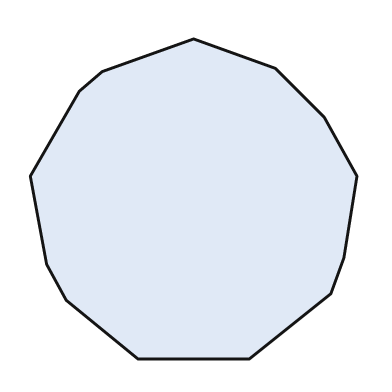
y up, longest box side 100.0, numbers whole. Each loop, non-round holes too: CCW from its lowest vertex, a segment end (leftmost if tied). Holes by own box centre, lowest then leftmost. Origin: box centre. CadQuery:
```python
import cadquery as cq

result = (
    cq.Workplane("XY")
    .moveTo(-17.0, -49.0)
    .lineTo(17.0, -49.0)
    .lineTo(42.0, -29.0)
    .lineTo(46.0, -18.0)
    .lineTo(50.0, 7.0)
    .lineTo(40.0, 25.0)
    .lineTo(25.0, 40.0)
    .lineTo(0.0, 49.0)
    .lineTo(-28.0, 39.0)
    .lineTo(-35.0, 33.0)
    .lineTo(-50.0, 7.0)
    .lineTo(-45.0, -20.0)
    .lineTo(-39.0, -31.0)
    .close()
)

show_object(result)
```